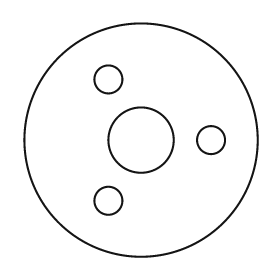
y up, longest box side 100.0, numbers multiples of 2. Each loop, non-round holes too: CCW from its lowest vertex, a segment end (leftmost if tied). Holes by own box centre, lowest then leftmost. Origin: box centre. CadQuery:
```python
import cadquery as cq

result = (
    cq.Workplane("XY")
    .moveTo(0.0, 0.0)
    .circle(50.0)
    .moveTo(-14.0, -26.0)
    .circle(6.0)
    .moveTo(0.0, 0.0)
    .circle(14.0)
    .moveTo(30.0, 0.0)
    .circle(6.0)
    .moveTo(-14.0, 26.0)
    .circle(6.0)
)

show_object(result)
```